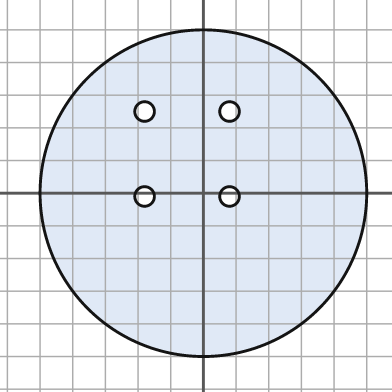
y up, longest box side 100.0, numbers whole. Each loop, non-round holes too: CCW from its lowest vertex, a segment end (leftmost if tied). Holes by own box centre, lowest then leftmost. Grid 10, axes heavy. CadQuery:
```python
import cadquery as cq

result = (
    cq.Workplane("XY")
    .moveTo(0.0, 0.0)
    .circle(50.0)
    .moveTo(-18.0, -1.0)
    .circle(3.0)
    .moveTo(8.0, -1.0)
    .circle(3.0)
    .moveTo(-18.0, 25.0)
    .circle(3.0)
    .moveTo(8.0, 25.0)
    .circle(3.0)
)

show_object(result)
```